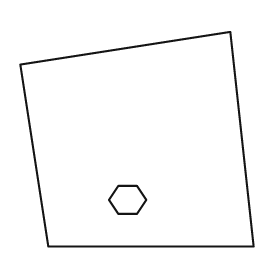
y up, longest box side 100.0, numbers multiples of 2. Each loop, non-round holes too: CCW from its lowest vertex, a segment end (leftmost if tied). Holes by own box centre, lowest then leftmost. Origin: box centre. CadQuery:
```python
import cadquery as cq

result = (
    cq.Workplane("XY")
    .moveTo(-38.0, -46.0)
    .lineTo(50.0, -46.0)
    .lineTo(40.0, 46.0)
    .lineTo(-50.0, 32.0)
    .close()
    .moveTo(-8.0, -32.0)
    .lineTo(0.0, -32.0)
    .lineTo(4.0, -26.0)
    .lineTo(0.0, -20.0)
    .lineTo(-8.0, -20.0)
    .lineTo(-12.0, -26.0)
    .close()
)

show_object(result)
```